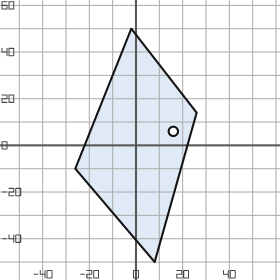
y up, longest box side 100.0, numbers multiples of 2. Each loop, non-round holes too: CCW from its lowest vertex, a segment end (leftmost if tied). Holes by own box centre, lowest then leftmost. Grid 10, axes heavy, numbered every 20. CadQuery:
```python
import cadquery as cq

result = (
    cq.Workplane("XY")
    .moveTo(8.0, -50.0)
    .lineTo(26.0, 14.0)
    .lineTo(-2.0, 50.0)
    .lineTo(-26.0, -10.0)
    .close()
    .moveTo(16.0, 6.0)
    .circle(2.0)
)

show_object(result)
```